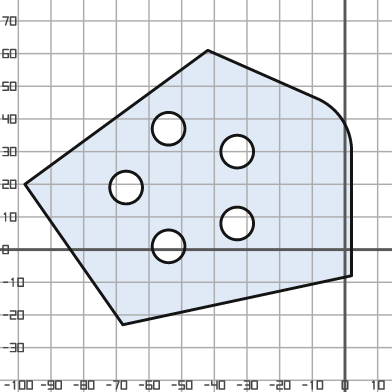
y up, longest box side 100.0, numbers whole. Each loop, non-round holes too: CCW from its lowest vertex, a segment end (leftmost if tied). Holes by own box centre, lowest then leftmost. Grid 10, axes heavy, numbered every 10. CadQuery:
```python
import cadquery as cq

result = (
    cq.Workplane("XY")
    .moveTo(-68.0, -23.0)
    .lineTo(2.0, -8.0)
    .lineTo(2.0, 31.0)
    .threePointArc((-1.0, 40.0), (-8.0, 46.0))
    .lineTo(-42.0, 61.0)
    .lineTo(-98.0, 20.0)
    .close()
    .moveTo(-54.0, 1.0)
    .circle(5.0)
    .moveTo(-33.0, 8.0)
    .circle(5.0)
    .moveTo(-67.0, 19.0)
    .circle(5.0)
    .moveTo(-33.0, 30.0)
    .circle(5.0)
    .moveTo(-54.0, 37.0)
    .circle(5.0)
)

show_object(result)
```